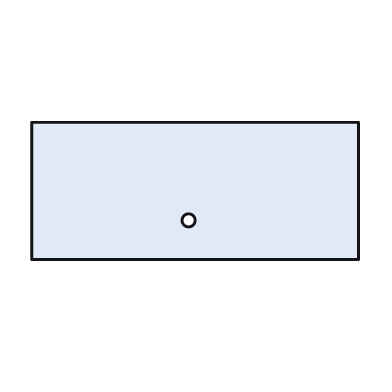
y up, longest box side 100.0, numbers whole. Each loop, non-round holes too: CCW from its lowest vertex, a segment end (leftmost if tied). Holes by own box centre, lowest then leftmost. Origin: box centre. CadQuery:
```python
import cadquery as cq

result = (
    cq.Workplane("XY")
    .moveTo(-50.0, -21.0)
    .lineTo(50.0, -21.0)
    .lineTo(50.0, 21.0)
    .lineTo(-50.0, 21.0)
    .close()
    .moveTo(-2.0, -9.0)
    .circle(2.0)
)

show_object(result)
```